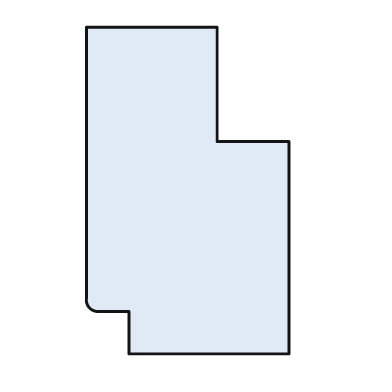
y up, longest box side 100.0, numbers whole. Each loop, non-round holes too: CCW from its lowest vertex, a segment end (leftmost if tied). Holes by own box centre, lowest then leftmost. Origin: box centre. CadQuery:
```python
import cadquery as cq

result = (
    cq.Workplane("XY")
    .moveTo(-18.0, -50.0)
    .lineTo(31.0, -50.0)
    .lineTo(31.0, 15.0)
    .lineTo(9.0, 15.0)
    .lineTo(9.0, 50.0)
    .lineTo(-31.0, 50.0)
    .lineTo(-31.0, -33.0)
    .threePointArc((-30.0, -36.0), (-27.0, -37.0))
    .lineTo(-18.0, -37.0)
    .close()
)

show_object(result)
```